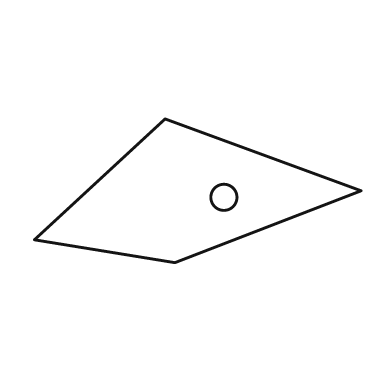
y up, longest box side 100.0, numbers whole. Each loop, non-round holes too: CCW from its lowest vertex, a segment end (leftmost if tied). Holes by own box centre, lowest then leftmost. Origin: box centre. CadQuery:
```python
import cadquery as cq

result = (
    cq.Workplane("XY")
    .moveTo(-7.0, -22.0)
    .lineTo(50.0, 0.0)
    .lineTo(-10.0, 22.0)
    .lineTo(-50.0, -15.0)
    .close()
    .moveTo(8.0, -2.0)
    .circle(4.0)
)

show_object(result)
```